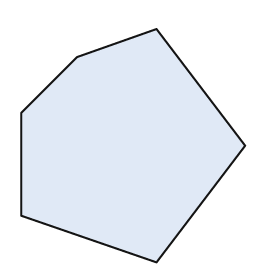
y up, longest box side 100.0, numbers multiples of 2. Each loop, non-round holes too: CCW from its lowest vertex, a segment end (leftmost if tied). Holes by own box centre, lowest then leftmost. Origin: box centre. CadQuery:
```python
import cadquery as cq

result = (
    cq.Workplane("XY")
    .moveTo(10.0, -50.0)
    .lineTo(48.0, 0.0)
    .lineTo(10.0, 50.0)
    .lineTo(-24.0, 38.0)
    .lineTo(-48.0, 14.0)
    .lineTo(-48.0, -30.0)
    .close()
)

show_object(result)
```